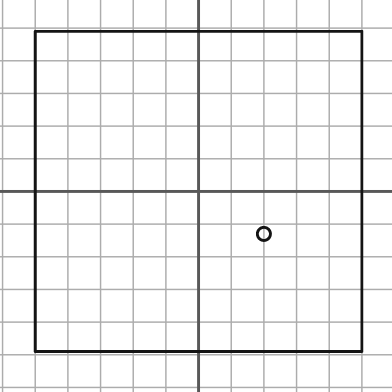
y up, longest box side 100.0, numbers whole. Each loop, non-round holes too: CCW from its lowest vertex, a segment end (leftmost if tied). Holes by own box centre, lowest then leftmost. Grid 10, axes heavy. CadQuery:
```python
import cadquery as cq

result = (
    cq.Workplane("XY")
    .moveTo(-50.0, -49.0)
    .lineTo(50.0, -49.0)
    .lineTo(50.0, 49.0)
    .lineTo(-50.0, 49.0)
    .close()
    .moveTo(20.0, -13.0)
    .circle(2.0)
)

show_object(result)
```